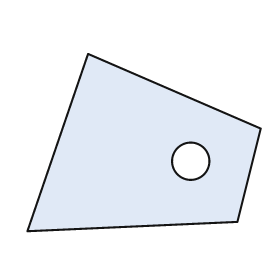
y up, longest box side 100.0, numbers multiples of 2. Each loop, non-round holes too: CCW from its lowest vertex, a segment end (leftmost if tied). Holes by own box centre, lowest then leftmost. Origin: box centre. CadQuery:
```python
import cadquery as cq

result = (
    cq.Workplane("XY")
    .moveTo(-50.0, -38.0)
    .lineTo(40.0, -34.0)
    .lineTo(50.0, 6.0)
    .lineTo(-24.0, 38.0)
    .close()
    .moveTo(20.0, -8.0)
    .circle(8.0)
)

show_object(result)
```